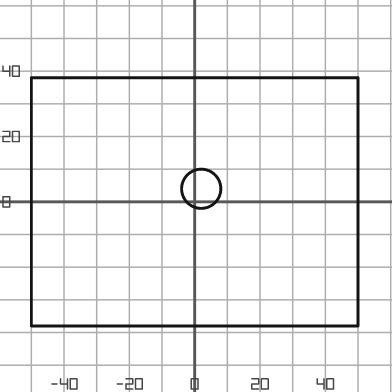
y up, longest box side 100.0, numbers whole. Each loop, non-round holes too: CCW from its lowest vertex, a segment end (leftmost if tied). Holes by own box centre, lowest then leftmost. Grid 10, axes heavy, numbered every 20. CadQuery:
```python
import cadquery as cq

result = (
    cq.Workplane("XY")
    .moveTo(-50.0, -38.0)
    .lineTo(50.0, -38.0)
    .lineTo(50.0, 38.0)
    .lineTo(-50.0, 38.0)
    .close()
    .moveTo(2.0, 4.0)
    .circle(6.0)
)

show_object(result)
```